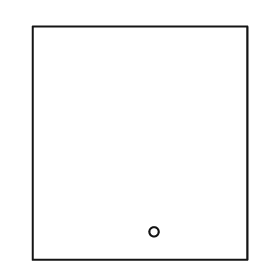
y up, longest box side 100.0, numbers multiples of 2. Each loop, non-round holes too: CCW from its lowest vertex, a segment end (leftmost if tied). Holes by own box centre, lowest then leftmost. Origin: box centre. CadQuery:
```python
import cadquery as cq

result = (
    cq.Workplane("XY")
    .moveTo(-46.0, -50.0)
    .lineTo(46.0, -50.0)
    .lineTo(46.0, 50.0)
    .lineTo(-46.0, 50.0)
    .close()
    .moveTo(6.0, -38.0)
    .circle(2.0)
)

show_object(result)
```